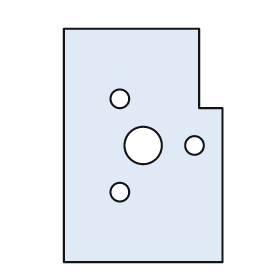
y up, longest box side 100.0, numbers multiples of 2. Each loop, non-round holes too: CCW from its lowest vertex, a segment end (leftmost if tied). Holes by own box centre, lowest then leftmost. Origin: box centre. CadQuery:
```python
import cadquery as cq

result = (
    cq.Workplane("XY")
    .moveTo(-34.0, -50.0)
    .lineTo(34.0, -50.0)
    .lineTo(34.0, 16.0)
    .lineTo(24.0, 16.0)
    .lineTo(24.0, 50.0)
    .lineTo(-34.0, 50.0)
    .close()
    .moveTo(-10.0, -20.0)
    .circle(4.0)
    .moveTo(0.0, 0.0)
    .circle(8.0)
    .moveTo(22.0, 0.0)
    .circle(4.0)
    .moveTo(-10.0, 20.0)
    .circle(4.0)
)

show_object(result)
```